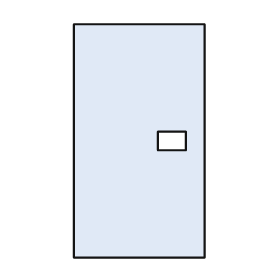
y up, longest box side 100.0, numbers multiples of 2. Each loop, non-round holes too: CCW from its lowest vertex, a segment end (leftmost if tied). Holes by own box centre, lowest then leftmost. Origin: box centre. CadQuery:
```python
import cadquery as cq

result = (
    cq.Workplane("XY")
    .moveTo(-28.0, -50.0)
    .lineTo(28.0, -50.0)
    .lineTo(28.0, 50.0)
    .lineTo(-28.0, 50.0)
    .close()
    .moveTo(8.0, -4.0)
    .lineTo(20.0, -4.0)
    .lineTo(20.0, 4.0)
    .lineTo(8.0, 4.0)
    .close()
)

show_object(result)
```